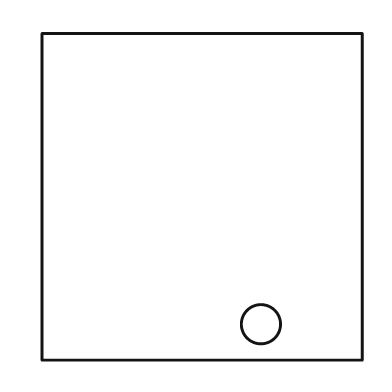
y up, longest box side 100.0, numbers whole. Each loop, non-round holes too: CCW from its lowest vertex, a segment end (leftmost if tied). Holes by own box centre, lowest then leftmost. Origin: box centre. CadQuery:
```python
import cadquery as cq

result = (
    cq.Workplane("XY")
    .moveTo(-49.0, -50.0)
    .lineTo(49.0, -50.0)
    .lineTo(49.0, 50.0)
    .lineTo(-49.0, 50.0)
    .close()
    .moveTo(18.0, -39.0)
    .circle(6.0)
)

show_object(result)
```